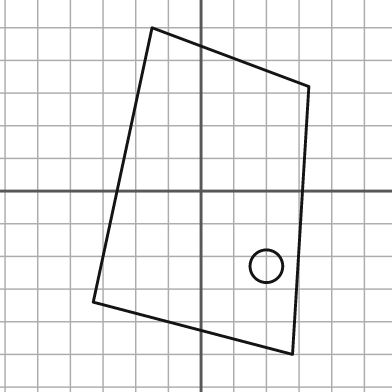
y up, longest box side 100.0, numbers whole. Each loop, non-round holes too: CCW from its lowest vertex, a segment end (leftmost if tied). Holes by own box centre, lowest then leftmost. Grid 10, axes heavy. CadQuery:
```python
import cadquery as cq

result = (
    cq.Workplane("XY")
    .moveTo(28.0, -50.0)
    .lineTo(33.0, 32.0)
    .lineTo(-15.0, 50.0)
    .lineTo(-33.0, -34.0)
    .close()
    .moveTo(20.0, -23.0)
    .circle(5.0)
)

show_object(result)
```